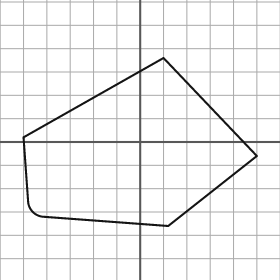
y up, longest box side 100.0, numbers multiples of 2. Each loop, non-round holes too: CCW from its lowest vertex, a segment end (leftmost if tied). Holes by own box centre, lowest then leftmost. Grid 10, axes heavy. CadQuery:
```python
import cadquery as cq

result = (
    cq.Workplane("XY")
    .moveTo(12.0, -36.0)
    .lineTo(50.0, -6.0)
    .lineTo(10.0, 36.0)
    .lineTo(-50.0, 2.0)
    .lineTo(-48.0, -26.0)
    .threePointArc((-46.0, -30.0), (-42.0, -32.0))
    .close()
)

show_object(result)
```